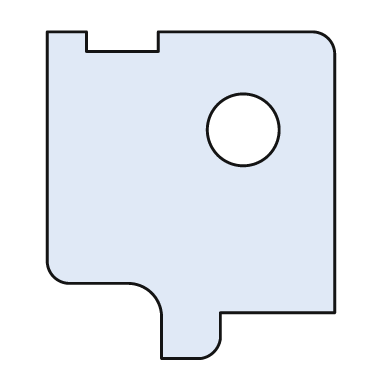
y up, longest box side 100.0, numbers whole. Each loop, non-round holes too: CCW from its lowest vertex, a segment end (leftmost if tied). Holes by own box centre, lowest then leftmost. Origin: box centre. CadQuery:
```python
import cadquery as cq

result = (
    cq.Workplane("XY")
    .moveTo(-9.0, -50.0)
    .lineTo(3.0, -50.0)
    .threePointArc((7.0, -48.0), (9.0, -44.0))
    .lineTo(9.0, -36.0)
    .lineTo(44.0, -36.0)
    .lineTo(44.0, 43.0)
    .threePointArc((42.0, 48.0), (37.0, 50.0))
    .lineTo(-10.0, 50.0)
    .lineTo(-10.0, 44.0)
    .lineTo(-32.0, 44.0)
    .lineTo(-32.0, 50.0)
    .lineTo(-44.0, 50.0)
    .lineTo(-44.0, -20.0)
    .threePointArc((-42.0, -25.0), (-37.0, -27.0))
    .lineTo(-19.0, -27.0)
    .threePointArc((-12.0, -30.0), (-9.0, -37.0))
    .close()
    .moveTo(16.0, 20.0)
    .circle(11.0)
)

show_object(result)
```